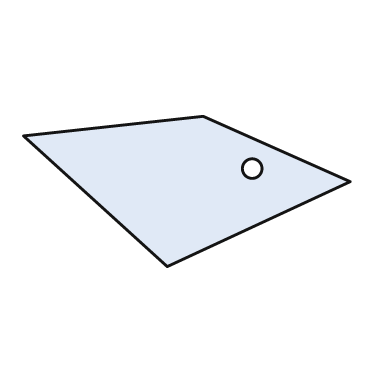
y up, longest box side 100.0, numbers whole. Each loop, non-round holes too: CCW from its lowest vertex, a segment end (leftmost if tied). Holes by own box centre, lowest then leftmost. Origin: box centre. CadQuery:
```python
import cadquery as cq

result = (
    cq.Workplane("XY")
    .moveTo(-6.0, -23.0)
    .lineTo(50.0, 3.0)
    .lineTo(5.0, 23.0)
    .lineTo(-50.0, 17.0)
    .close()
    .moveTo(20.0, 7.0)
    .circle(3.0)
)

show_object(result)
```